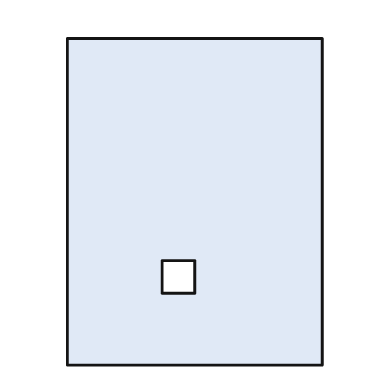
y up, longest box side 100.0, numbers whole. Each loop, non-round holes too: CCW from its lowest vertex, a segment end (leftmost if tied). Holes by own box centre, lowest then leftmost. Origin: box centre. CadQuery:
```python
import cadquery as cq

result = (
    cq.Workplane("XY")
    .moveTo(-39.0, -50.0)
    .lineTo(39.0, -50.0)
    .lineTo(39.0, 50.0)
    .lineTo(-39.0, 50.0)
    .close()
    .moveTo(-10.0, -28.0)
    .lineTo(0.0, -28.0)
    .lineTo(0.0, -18.0)
    .lineTo(-10.0, -18.0)
    .close()
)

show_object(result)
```